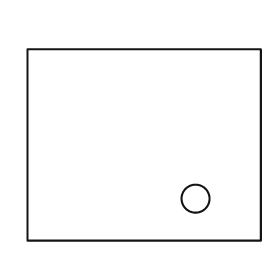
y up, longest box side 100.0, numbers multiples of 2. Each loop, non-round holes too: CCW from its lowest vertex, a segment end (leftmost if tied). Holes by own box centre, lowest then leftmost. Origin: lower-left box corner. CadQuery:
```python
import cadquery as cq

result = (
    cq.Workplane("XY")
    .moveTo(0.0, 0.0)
    .lineTo(100.0, 0.0)
    .lineTo(100.0, 82.0)
    .lineTo(0.0, 82.0)
    .close()
    .moveTo(72.0, 18.0)
    .circle(6.0)
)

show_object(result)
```